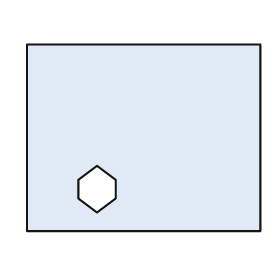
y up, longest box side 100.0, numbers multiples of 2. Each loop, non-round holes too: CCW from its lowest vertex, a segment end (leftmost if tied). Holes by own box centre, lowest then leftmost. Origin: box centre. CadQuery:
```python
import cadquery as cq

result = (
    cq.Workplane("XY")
    .moveTo(-50.0, -40.0)
    .lineTo(50.0, -40.0)
    .lineTo(50.0, 40.0)
    .lineTo(-50.0, 40.0)
    .close()
    .moveTo(-20.0, -32.0)
    .lineTo(-12.0, -26.0)
    .lineTo(-12.0, -18.0)
    .lineTo(-20.0, -12.0)
    .lineTo(-28.0, -18.0)
    .lineTo(-28.0, -26.0)
    .close()
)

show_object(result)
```